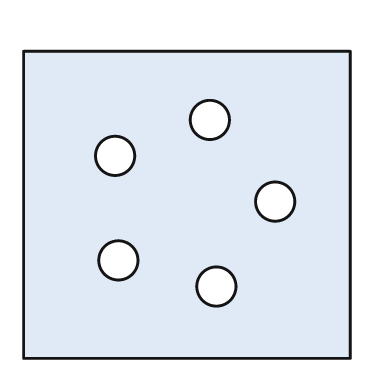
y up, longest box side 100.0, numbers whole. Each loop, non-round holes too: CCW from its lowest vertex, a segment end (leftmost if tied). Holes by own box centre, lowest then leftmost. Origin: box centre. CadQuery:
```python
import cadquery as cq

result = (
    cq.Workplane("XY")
    .moveTo(-50.0, -47.0)
    .lineTo(50.0, -47.0)
    .lineTo(50.0, 47.0)
    .lineTo(-50.0, 47.0)
    .close()
    .moveTo(9.0, -25.0)
    .circle(6.0)
    .moveTo(-21.0, -17.0)
    .circle(6.0)
    .moveTo(27.0, 1.0)
    .circle(6.0)
    .moveTo(-22.0, 15.0)
    .circle(6.0)
    .moveTo(7.0, 26.0)
    .circle(6.0)
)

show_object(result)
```